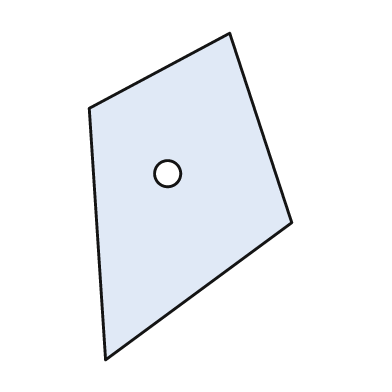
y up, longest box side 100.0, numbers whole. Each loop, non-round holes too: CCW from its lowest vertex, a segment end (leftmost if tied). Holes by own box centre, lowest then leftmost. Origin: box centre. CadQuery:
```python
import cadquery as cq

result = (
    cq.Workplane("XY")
    .moveTo(-26.0, -50.0)
    .lineTo(31.0, -8.0)
    .lineTo(12.0, 50.0)
    .lineTo(-31.0, 27.0)
    .close()
    .moveTo(-7.0, 7.0)
    .circle(4.0)
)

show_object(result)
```